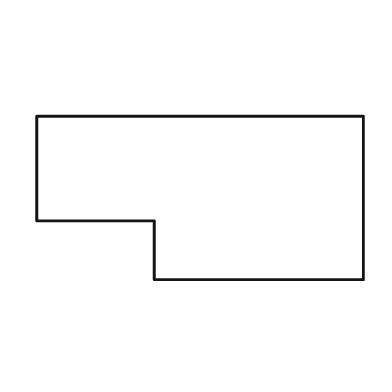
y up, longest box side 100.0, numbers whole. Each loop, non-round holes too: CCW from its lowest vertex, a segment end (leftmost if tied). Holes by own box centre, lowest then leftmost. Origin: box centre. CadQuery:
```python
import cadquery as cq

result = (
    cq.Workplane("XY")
    .moveTo(-14.0, -25.0)
    .lineTo(50.0, -25.0)
    .lineTo(50.0, 25.0)
    .lineTo(-50.0, 25.0)
    .lineTo(-50.0, -7.0)
    .lineTo(-14.0, -7.0)
    .close()
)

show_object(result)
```